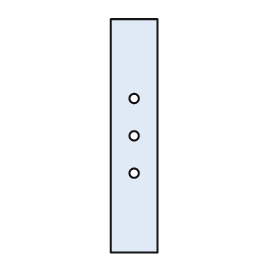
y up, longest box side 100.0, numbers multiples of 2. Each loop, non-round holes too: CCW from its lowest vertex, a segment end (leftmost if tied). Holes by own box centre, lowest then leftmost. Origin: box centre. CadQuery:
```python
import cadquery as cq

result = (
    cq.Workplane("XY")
    .moveTo(-10.0, -50.0)
    .lineTo(10.0, -50.0)
    .lineTo(10.0, 50.0)
    .lineTo(-10.0, 50.0)
    .close()
    .moveTo(0.0, -16.0)
    .circle(2.0)
    .moveTo(0.0, 0.0)
    .circle(2.0)
    .moveTo(0.0, 16.0)
    .circle(2.0)
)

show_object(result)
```